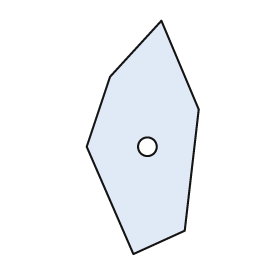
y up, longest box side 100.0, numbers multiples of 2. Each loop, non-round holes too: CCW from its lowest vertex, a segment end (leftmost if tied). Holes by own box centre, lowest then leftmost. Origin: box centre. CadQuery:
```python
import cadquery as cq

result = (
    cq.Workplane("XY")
    .moveTo(-4.0, -50.0)
    .lineTo(18.0, -40.0)
    .lineTo(24.0, 12.0)
    .lineTo(8.0, 50.0)
    .lineTo(-14.0, 26.0)
    .lineTo(-24.0, -4.0)
    .close()
    .moveTo(2.0, -4.0)
    .circle(4.0)
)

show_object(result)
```